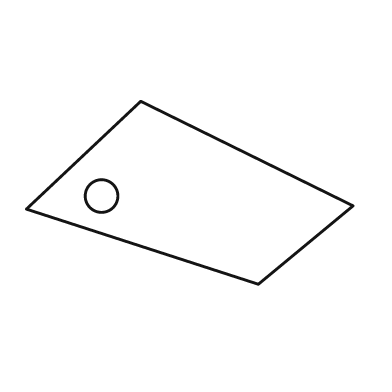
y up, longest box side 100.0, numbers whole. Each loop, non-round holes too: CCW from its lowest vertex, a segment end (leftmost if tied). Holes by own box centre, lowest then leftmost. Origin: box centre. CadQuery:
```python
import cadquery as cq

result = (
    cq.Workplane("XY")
    .moveTo(21.0, -28.0)
    .lineTo(50.0, -4.0)
    .lineTo(-15.0, 28.0)
    .lineTo(-50.0, -5.0)
    .close()
    .moveTo(-27.0, -1.0)
    .circle(5.0)
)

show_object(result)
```